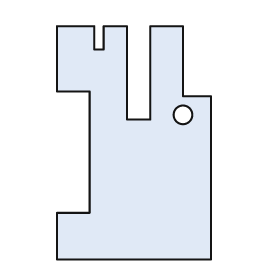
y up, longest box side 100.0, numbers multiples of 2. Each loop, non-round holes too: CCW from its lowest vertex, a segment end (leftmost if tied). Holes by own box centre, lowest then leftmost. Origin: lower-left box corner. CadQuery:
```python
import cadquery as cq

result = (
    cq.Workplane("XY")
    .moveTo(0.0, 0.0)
    .lineTo(66.0, 0.0)
    .lineTo(66.0, 70.0)
    .lineTo(54.0, 70.0)
    .lineTo(54.0, 100.0)
    .lineTo(40.0, 100.0)
    .lineTo(40.0, 60.0)
    .lineTo(30.0, 60.0)
    .lineTo(30.0, 100.0)
    .lineTo(20.0, 100.0)
    .lineTo(20.0, 90.0)
    .lineTo(16.0, 90.0)
    .lineTo(16.0, 100.0)
    .lineTo(0.0, 100.0)
    .lineTo(0.0, 72.0)
    .lineTo(14.0, 72.0)
    .lineTo(14.0, 20.0)
    .lineTo(0.0, 20.0)
    .close()
    .moveTo(54.0, 62.0)
    .circle(4.0)
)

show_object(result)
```